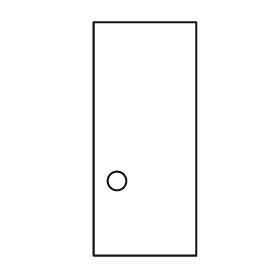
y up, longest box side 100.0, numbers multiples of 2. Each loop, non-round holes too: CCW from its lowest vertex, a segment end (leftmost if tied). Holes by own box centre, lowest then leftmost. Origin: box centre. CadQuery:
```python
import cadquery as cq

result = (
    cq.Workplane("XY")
    .moveTo(-22.0, -50.0)
    .lineTo(22.0, -50.0)
    .lineTo(22.0, 50.0)
    .lineTo(-22.0, 50.0)
    .close()
    .moveTo(-12.0, -18.0)
    .circle(4.0)
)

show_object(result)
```